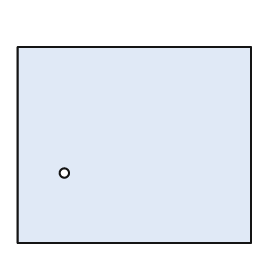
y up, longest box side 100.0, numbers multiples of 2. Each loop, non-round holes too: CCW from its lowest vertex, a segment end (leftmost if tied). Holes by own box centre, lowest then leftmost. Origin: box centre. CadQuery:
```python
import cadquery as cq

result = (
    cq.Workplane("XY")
    .moveTo(-50.0, -42.0)
    .lineTo(50.0, -42.0)
    .lineTo(50.0, 42.0)
    .lineTo(-50.0, 42.0)
    .close()
    .moveTo(-30.0, -12.0)
    .circle(2.0)
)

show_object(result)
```